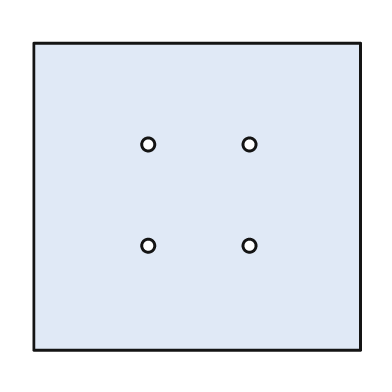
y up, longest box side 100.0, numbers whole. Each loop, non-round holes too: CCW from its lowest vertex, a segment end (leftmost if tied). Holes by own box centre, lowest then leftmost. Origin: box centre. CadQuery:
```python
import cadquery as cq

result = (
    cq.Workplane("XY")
    .moveTo(-50.0, -47.0)
    .lineTo(50.0, -47.0)
    .lineTo(50.0, 47.0)
    .lineTo(-50.0, 47.0)
    .close()
    .moveTo(-15.0, -15.0)
    .circle(2.0)
    .moveTo(16.0, -15.0)
    .circle(2.0)
    .moveTo(-15.0, 16.0)
    .circle(2.0)
    .moveTo(16.0, 16.0)
    .circle(2.0)
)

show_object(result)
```